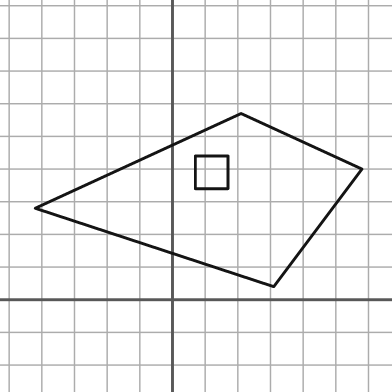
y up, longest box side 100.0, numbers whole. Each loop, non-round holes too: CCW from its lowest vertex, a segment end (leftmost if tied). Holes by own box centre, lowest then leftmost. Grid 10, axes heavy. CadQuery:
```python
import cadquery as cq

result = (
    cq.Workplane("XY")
    .moveTo(31.0, 4.0)
    .lineTo(58.0, 40.0)
    .lineTo(21.0, 57.0)
    .lineTo(-42.0, 28.0)
    .close()
    .moveTo(7.0, 34.0)
    .lineTo(17.0, 34.0)
    .lineTo(17.0, 44.0)
    .lineTo(7.0, 44.0)
    .close()
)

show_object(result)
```